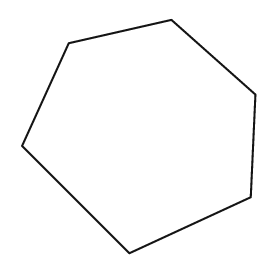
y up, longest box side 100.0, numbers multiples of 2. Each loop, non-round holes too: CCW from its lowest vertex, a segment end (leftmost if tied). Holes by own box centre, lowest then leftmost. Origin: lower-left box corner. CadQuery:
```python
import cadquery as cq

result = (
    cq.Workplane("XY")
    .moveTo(46.0, 0.0)
    .lineTo(98.0, 24.0)
    .lineTo(100.0, 68.0)
    .lineTo(64.0, 100.0)
    .lineTo(20.0, 90.0)
    .lineTo(0.0, 46.0)
    .close()
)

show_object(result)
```